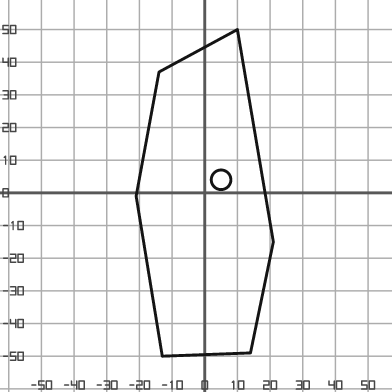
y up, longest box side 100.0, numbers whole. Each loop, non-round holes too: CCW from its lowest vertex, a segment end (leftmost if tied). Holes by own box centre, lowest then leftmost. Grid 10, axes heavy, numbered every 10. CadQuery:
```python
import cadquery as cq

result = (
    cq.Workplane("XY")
    .moveTo(-13.0, -50.0)
    .lineTo(14.0, -49.0)
    .lineTo(21.0, -15.0)
    .lineTo(10.0, 50.0)
    .lineTo(-14.0, 37.0)
    .lineTo(-21.0, -1.0)
    .close()
    .moveTo(5.0, 4.0)
    .circle(3.0)
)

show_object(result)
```